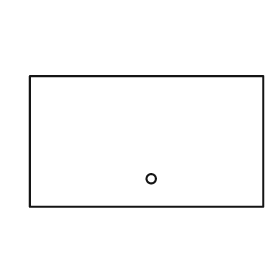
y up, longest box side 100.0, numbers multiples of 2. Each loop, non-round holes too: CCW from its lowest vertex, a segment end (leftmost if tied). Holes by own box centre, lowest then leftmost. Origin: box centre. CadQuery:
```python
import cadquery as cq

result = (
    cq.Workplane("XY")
    .moveTo(-50.0, -28.0)
    .lineTo(50.0, -28.0)
    .lineTo(50.0, 28.0)
    .lineTo(-50.0, 28.0)
    .close()
    .moveTo(2.0, -16.0)
    .circle(2.0)
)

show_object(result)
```